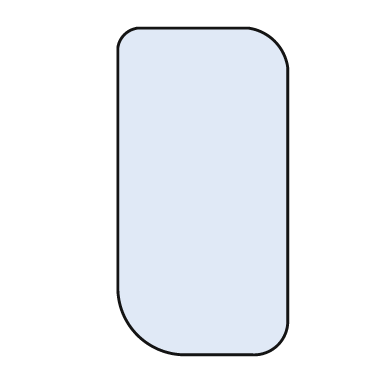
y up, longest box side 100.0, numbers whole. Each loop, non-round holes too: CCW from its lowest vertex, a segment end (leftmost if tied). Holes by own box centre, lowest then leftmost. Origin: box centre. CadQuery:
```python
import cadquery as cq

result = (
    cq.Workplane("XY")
    .moveTo(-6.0, -50.0)
    .lineTo(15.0, -50.0)
    .threePointArc((23.0, -47.0), (26.0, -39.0))
    .lineTo(26.0, 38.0)
    .threePointArc((22.0, 46.0), (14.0, 50.0))
    .lineTo(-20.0, 50.0)
    .threePointArc((-24.0, 48.0), (-26.0, 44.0))
    .lineTo(-26.0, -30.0)
    .threePointArc((-20.0, -44.0), (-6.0, -50.0))
    .close()
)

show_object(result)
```